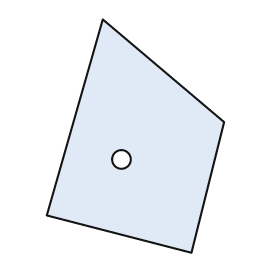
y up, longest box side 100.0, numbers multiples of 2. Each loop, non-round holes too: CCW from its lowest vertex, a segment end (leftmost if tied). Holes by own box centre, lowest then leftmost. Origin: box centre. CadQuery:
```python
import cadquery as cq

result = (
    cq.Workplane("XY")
    .moveTo(24.0, -50.0)
    .lineTo(38.0, 6.0)
    .lineTo(-14.0, 50.0)
    .lineTo(-38.0, -34.0)
    .close()
    .moveTo(-6.0, -10.0)
    .circle(4.0)
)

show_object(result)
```